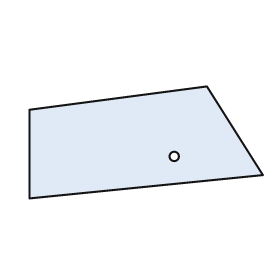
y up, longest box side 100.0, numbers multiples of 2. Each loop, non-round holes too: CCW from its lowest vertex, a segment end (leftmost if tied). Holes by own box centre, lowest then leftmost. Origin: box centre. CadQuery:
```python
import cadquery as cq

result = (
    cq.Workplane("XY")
    .moveTo(-50.0, -24.0)
    .lineTo(50.0, -14.0)
    .lineTo(26.0, 24.0)
    .lineTo(-50.0, 14.0)
    .close()
    .moveTo(12.0, -6.0)
    .circle(2.0)
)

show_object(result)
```